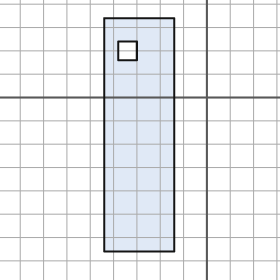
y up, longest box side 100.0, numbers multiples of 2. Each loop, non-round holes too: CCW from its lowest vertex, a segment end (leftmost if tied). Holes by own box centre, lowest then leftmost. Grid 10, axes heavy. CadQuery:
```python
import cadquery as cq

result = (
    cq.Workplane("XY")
    .moveTo(-44.0, -66.0)
    .lineTo(-14.0, -66.0)
    .lineTo(-14.0, 34.0)
    .lineTo(-44.0, 34.0)
    .close()
    .moveTo(-38.0, 16.0)
    .lineTo(-30.0, 16.0)
    .lineTo(-30.0, 24.0)
    .lineTo(-38.0, 24.0)
    .close()
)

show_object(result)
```